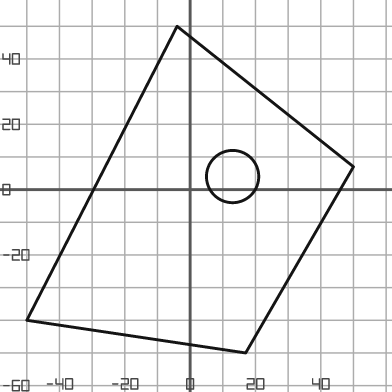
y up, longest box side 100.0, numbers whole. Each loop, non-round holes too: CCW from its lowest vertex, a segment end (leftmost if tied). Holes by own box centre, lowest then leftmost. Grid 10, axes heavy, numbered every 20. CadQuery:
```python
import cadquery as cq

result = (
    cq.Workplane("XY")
    .moveTo(17.0, -50.0)
    .lineTo(50.0, 7.0)
    .lineTo(-4.0, 50.0)
    .lineTo(-50.0, -40.0)
    .close()
    .moveTo(13.0, 4.0)
    .circle(8.0)
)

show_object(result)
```